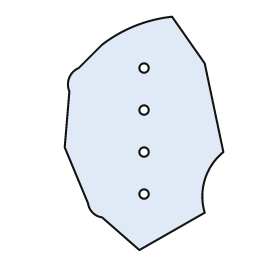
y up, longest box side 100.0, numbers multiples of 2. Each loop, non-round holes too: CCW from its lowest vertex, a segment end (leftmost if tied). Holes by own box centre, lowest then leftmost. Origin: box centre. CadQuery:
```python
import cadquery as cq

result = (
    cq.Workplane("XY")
    .moveTo(-2.0, -50.0)
    .lineTo(26.0, -34.0)
    .threePointArc((26.0, -20.0), (34.0, -8.0))
    .lineTo(26.0, 30.0)
    .lineTo(12.0, 50.0)
    .threePointArc((-4.0, 46.0), (-18.0, 38.0))
    .lineTo(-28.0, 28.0)
    .threePointArc((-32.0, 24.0), (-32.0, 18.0))
    .lineTo(-34.0, -6.0)
    .lineTo(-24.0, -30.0)
    .threePointArc((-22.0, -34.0), (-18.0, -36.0))
    .close()
    .moveTo(0.0, -26.0)
    .circle(2.0)
    .moveTo(0.0, -8.0)
    .circle(2.0)
    .moveTo(0.0, 10.0)
    .circle(2.0)
    .moveTo(0.0, 28.0)
    .circle(2.0)
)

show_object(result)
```